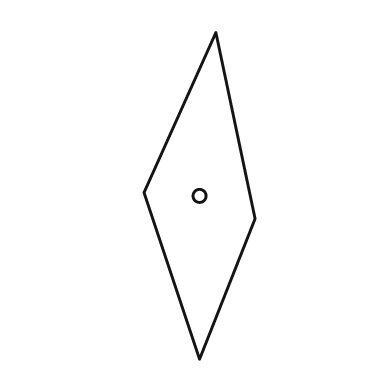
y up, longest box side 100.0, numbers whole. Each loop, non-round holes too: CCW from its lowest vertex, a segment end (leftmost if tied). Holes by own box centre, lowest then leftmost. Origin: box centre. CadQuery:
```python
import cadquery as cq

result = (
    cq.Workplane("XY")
    .moveTo(0.0, -50.0)
    .lineTo(17.0, -7.0)
    .lineTo(5.0, 50.0)
    .lineTo(-17.0, 1.0)
    .close()
    .moveTo(0.0, 0.0)
    .circle(2.0)
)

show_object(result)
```